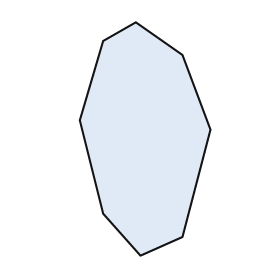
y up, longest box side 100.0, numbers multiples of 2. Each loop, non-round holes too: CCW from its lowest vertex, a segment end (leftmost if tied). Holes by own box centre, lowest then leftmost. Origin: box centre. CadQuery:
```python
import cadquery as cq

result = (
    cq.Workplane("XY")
    .moveTo(-2.0, -50.0)
    .lineTo(16.0, -42.0)
    .lineTo(28.0, 4.0)
    .lineTo(16.0, 36.0)
    .lineTo(-4.0, 50.0)
    .lineTo(-18.0, 42.0)
    .lineTo(-28.0, 8.0)
    .lineTo(-18.0, -32.0)
    .close()
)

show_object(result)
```